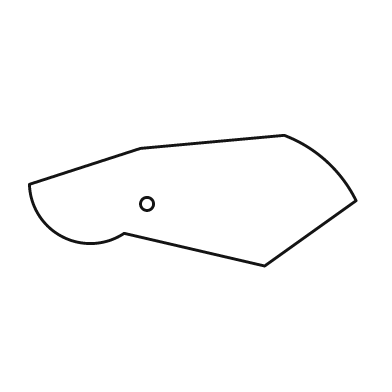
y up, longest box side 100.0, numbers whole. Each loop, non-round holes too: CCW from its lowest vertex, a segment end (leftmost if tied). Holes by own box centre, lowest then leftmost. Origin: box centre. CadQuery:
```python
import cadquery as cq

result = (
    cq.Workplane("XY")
    .moveTo(22.0, -20.0)
    .lineTo(50.0, 0.0)
    .threePointArc((41.0, 12.0), (28.0, 20.0))
    .lineTo(-16.0, 16.0)
    .lineTo(-50.0, 5.0)
    .threePointArc((-40.0, -11.0), (-21.0, -10.0))
    .close()
    .moveTo(-14.0, -1.0)
    .circle(2.0)
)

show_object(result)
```